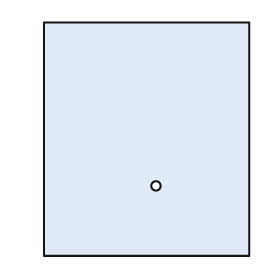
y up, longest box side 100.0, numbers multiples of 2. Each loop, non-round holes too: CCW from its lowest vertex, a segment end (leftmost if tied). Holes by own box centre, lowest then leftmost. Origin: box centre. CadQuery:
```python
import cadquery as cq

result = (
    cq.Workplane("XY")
    .moveTo(-44.0, -50.0)
    .lineTo(44.0, -50.0)
    .lineTo(44.0, 50.0)
    .lineTo(-44.0, 50.0)
    .close()
    .moveTo(4.0, -20.0)
    .circle(2.0)
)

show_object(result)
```